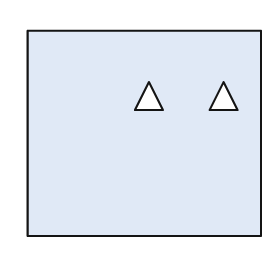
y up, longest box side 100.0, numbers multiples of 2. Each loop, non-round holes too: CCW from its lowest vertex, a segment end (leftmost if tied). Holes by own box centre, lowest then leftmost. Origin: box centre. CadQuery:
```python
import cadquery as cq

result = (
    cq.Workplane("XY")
    .moveTo(-50.0, -44.0)
    .lineTo(50.0, -44.0)
    .lineTo(50.0, 44.0)
    .lineTo(-50.0, 44.0)
    .close()
    .moveTo(-4.0, 10.0)
    .lineTo(8.0, 10.0)
    .lineTo(2.0, 22.0)
    .close()
    .moveTo(28.0, 10.0)
    .lineTo(40.0, 10.0)
    .lineTo(34.0, 22.0)
    .close()
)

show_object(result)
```